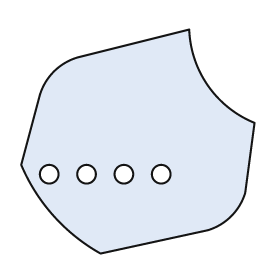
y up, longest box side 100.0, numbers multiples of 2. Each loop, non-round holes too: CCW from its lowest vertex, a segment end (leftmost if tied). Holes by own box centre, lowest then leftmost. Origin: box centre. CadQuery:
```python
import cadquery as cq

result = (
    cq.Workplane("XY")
    .moveTo(-16.0, -48.0)
    .lineTo(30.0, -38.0)
    .threePointArc((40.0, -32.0), (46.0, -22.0))
    .lineTo(50.0, 8.0)
    .threePointArc((30.0, 24.0), (22.0, 48.0))
    .lineTo(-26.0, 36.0)
    .threePointArc((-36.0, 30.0), (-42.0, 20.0))
    .lineTo(-50.0, -10.0)
    .threePointArc((-36.0, -32.0), (-16.0, -48.0))
    .close()
    .moveTo(-38.0, -14.0)
    .circle(4.0)
    .moveTo(-22.0, -14.0)
    .circle(4.0)
    .moveTo(-6.0, -14.0)
    .circle(4.0)
    .moveTo(10.0, -14.0)
    .circle(4.0)
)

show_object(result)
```